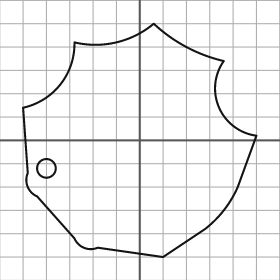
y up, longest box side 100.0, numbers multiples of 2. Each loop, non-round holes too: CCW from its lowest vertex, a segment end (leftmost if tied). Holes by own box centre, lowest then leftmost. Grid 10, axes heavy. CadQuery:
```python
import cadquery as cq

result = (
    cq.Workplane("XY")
    .moveTo(10.0, -50.0)
    .lineTo(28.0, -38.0)
    .threePointArc((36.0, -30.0), (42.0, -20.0))
    .lineTo(50.0, 2.0)
    .threePointArc((34.0, 14.0), (36.0, 34.0))
    .threePointArc((20.0, 40.0), (6.0, 50.0))
    .threePointArc((-10.0, 42.0), (-28.0, 42.0))
    .threePointArc((-34.0, 24.0), (-50.0, 14.0))
    .lineTo(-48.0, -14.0)
    .threePointArc((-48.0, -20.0), (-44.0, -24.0))
    .lineTo(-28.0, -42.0)
    .threePointArc((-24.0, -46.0), (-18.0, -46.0))
    .close()
    .moveTo(-40.0, -12.0)
    .circle(4.0)
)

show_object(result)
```